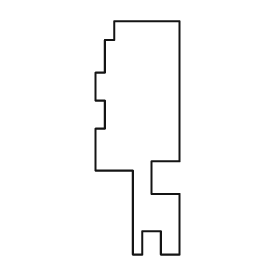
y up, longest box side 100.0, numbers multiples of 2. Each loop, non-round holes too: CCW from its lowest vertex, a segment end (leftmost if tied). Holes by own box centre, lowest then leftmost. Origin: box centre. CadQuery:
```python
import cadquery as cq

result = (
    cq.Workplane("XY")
    .moveTo(-2.0, -50.0)
    .lineTo(2.0, -50.0)
    .lineTo(2.0, -40.0)
    .lineTo(10.0, -40.0)
    .lineTo(10.0, -50.0)
    .lineTo(18.0, -50.0)
    .lineTo(18.0, -24.0)
    .lineTo(6.0, -24.0)
    .lineTo(6.0, -10.0)
    .lineTo(18.0, -10.0)
    .lineTo(18.0, 50.0)
    .lineTo(-10.0, 50.0)
    .lineTo(-10.0, 42.0)
    .lineTo(-14.0, 42.0)
    .lineTo(-14.0, 28.0)
    .lineTo(-18.0, 28.0)
    .lineTo(-18.0, 16.0)
    .lineTo(-14.0, 16.0)
    .lineTo(-14.0, 4.0)
    .lineTo(-18.0, 4.0)
    .lineTo(-18.0, -14.0)
    .lineTo(-2.0, -14.0)
    .close()
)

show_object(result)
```